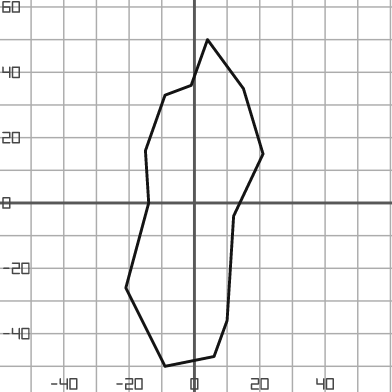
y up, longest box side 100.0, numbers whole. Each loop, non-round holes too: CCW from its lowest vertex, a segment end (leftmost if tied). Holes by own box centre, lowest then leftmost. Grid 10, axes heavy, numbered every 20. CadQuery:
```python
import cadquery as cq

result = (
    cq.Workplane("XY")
    .moveTo(-9.0, -50.0)
    .lineTo(6.0, -47.0)
    .lineTo(10.0, -36.0)
    .lineTo(12.0, -4.0)
    .lineTo(21.0, 15.0)
    .lineTo(15.0, 35.0)
    .lineTo(4.0, 50.0)
    .lineTo(-1.0, 36.0)
    .lineTo(-9.0, 33.0)
    .lineTo(-15.0, 16.0)
    .lineTo(-14.0, 0.0)
    .lineTo(-21.0, -26.0)
    .close()
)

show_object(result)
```